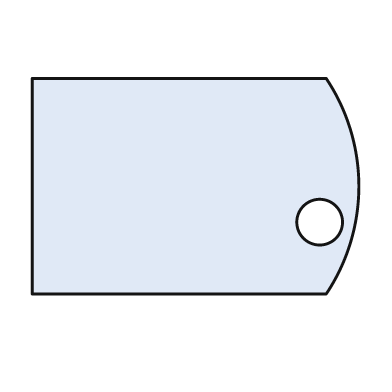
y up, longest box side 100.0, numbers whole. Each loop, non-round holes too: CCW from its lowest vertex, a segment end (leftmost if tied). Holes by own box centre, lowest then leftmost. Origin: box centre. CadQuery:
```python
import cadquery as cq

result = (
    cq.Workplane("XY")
    .moveTo(-50.0, -33.0)
    .lineTo(40.0, -33.0)
    .threePointArc((50.0, 0.0), (40.0, 33.0))
    .lineTo(-50.0, 33.0)
    .close()
    .moveTo(38.0, -11.0)
    .circle(7.0)
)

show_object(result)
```